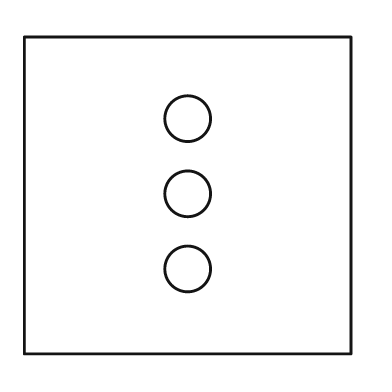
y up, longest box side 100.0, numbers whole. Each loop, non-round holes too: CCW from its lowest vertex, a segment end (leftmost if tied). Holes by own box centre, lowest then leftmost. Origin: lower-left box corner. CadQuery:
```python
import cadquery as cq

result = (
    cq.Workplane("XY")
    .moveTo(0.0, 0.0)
    .lineTo(100.0, 0.0)
    .lineTo(100.0, 97.0)
    .lineTo(0.0, 97.0)
    .close()
    .moveTo(50.0, 26.0)
    .circle(7.0)
    .moveTo(50.0, 49.0)
    .circle(7.0)
    .moveTo(50.0, 72.0)
    .circle(7.0)
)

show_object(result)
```